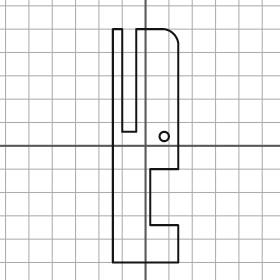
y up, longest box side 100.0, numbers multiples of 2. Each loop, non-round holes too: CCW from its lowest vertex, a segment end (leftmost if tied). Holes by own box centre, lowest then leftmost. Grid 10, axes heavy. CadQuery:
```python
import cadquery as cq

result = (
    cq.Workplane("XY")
    .moveTo(-14.0, -50.0)
    .lineTo(14.0, -50.0)
    .lineTo(14.0, -34.0)
    .lineTo(2.0, -34.0)
    .lineTo(2.0, -10.0)
    .lineTo(14.0, -10.0)
    .lineTo(14.0, 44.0)
    .threePointArc((12.0, 48.0), (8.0, 50.0))
    .lineTo(-4.0, 50.0)
    .lineTo(-4.0, 6.0)
    .lineTo(-10.0, 6.0)
    .lineTo(-10.0, 50.0)
    .lineTo(-14.0, 50.0)
    .close()
    .moveTo(8.0, 4.0)
    .circle(2.0)
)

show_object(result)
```